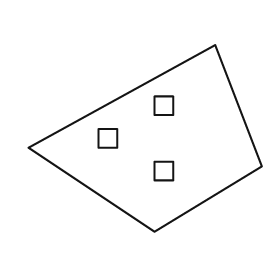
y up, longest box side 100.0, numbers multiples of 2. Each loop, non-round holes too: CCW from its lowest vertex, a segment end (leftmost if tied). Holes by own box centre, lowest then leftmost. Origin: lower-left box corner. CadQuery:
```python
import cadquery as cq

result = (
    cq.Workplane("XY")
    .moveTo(54.0, 0.0)
    .lineTo(100.0, 28.0)
    .lineTo(80.0, 80.0)
    .lineTo(0.0, 36.0)
    .close()
    .moveTo(54.0, 22.0)
    .lineTo(62.0, 22.0)
    .lineTo(62.0, 30.0)
    .lineTo(54.0, 30.0)
    .close()
    .moveTo(30.0, 36.0)
    .lineTo(38.0, 36.0)
    .lineTo(38.0, 44.0)
    .lineTo(30.0, 44.0)
    .close()
    .moveTo(54.0, 50.0)
    .lineTo(62.0, 50.0)
    .lineTo(62.0, 58.0)
    .lineTo(54.0, 58.0)
    .close()
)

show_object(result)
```